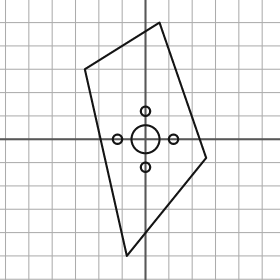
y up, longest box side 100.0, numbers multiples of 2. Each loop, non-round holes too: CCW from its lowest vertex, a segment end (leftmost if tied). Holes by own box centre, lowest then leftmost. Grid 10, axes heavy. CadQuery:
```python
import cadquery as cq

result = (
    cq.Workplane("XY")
    .moveTo(-8.0, -50.0)
    .lineTo(26.0, -8.0)
    .lineTo(6.0, 50.0)
    .lineTo(-26.0, 30.0)
    .close()
    .moveTo(0.0, -12.0)
    .circle(2.0)
    .moveTo(-12.0, 0.0)
    .circle(2.0)
    .moveTo(0.0, 0.0)
    .circle(6.0)
    .moveTo(12.0, 0.0)
    .circle(2.0)
    .moveTo(0.0, 12.0)
    .circle(2.0)
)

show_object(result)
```